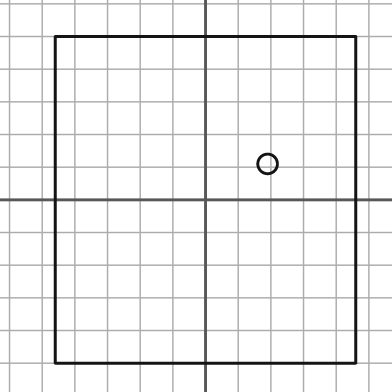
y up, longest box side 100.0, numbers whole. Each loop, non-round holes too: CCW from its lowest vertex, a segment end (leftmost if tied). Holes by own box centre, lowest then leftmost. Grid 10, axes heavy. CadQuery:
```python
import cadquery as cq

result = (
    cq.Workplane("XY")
    .moveTo(-46.0, -50.0)
    .lineTo(46.0, -50.0)
    .lineTo(46.0, 50.0)
    .lineTo(-46.0, 50.0)
    .close()
    .moveTo(19.0, 11.0)
    .circle(3.0)
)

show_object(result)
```